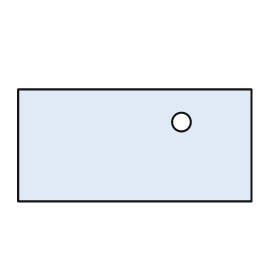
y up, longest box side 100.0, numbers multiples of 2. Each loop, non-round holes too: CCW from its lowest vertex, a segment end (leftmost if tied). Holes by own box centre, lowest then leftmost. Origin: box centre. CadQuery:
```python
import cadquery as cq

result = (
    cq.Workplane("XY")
    .moveTo(-50.0, -24.0)
    .lineTo(50.0, -24.0)
    .lineTo(50.0, 24.0)
    .lineTo(-50.0, 24.0)
    .close()
    .moveTo(20.0, 10.0)
    .circle(4.0)
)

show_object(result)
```